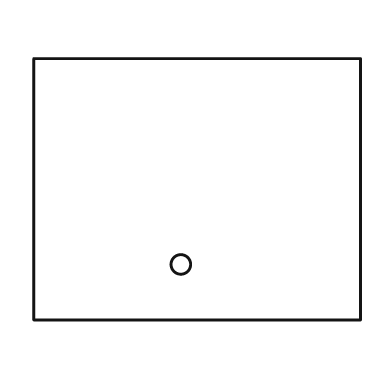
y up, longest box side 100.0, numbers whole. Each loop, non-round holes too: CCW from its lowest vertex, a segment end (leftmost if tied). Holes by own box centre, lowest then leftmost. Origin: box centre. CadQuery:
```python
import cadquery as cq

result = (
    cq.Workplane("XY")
    .moveTo(-50.0, -40.0)
    .lineTo(50.0, -40.0)
    .lineTo(50.0, 40.0)
    .lineTo(-50.0, 40.0)
    .close()
    .moveTo(-5.0, -23.0)
    .circle(3.0)
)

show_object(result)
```